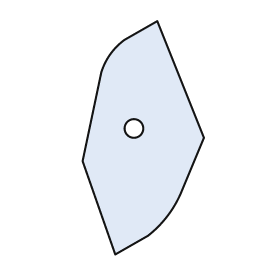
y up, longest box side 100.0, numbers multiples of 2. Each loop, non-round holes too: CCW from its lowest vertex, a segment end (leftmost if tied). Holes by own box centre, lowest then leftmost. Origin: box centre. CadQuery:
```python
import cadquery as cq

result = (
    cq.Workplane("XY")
    .moveTo(-12.0, -50.0)
    .lineTo(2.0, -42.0)
    .threePointArc((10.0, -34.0), (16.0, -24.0))
    .lineTo(26.0, 0.0)
    .lineTo(6.0, 50.0)
    .lineTo(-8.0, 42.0)
    .threePointArc((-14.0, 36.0), (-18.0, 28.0))
    .lineTo(-26.0, -10.0)
    .close()
    .moveTo(-4.0, 4.0)
    .circle(4.0)
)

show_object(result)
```